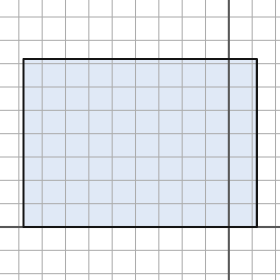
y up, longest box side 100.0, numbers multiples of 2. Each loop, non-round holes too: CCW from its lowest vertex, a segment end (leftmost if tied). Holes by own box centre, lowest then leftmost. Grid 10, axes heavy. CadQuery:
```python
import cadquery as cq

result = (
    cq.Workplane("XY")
    .moveTo(-88.0, 0.0)
    .lineTo(12.0, 0.0)
    .lineTo(12.0, 72.0)
    .lineTo(-88.0, 72.0)
    .close()
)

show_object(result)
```